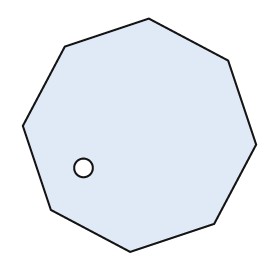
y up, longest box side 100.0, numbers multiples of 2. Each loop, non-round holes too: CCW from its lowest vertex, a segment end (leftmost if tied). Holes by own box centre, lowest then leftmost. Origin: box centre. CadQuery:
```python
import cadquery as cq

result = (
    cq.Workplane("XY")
    .moveTo(-4.0, -50.0)
    .lineTo(32.0, -38.0)
    .lineTo(50.0, -4.0)
    .lineTo(38.0, 32.0)
    .lineTo(4.0, 50.0)
    .lineTo(-32.0, 38.0)
    .lineTo(-50.0, 4.0)
    .lineTo(-38.0, -32.0)
    .close()
    .moveTo(-24.0, -14.0)
    .circle(4.0)
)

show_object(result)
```